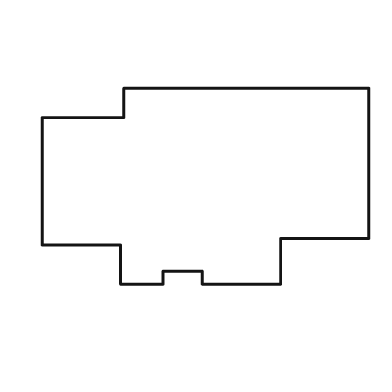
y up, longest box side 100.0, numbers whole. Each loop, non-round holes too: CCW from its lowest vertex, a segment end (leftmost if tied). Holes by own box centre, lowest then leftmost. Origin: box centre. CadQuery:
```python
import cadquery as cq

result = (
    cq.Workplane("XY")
    .moveTo(-26.0, -30.0)
    .lineTo(-13.0, -30.0)
    .lineTo(-13.0, -26.0)
    .lineTo(-1.0, -26.0)
    .lineTo(-1.0, -30.0)
    .lineTo(23.0, -30.0)
    .lineTo(23.0, -16.0)
    .lineTo(50.0, -16.0)
    .lineTo(50.0, 30.0)
    .lineTo(-25.0, 30.0)
    .lineTo(-25.0, 21.0)
    .lineTo(-50.0, 21.0)
    .lineTo(-50.0, -18.0)
    .lineTo(-26.0, -18.0)
    .close()
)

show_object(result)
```